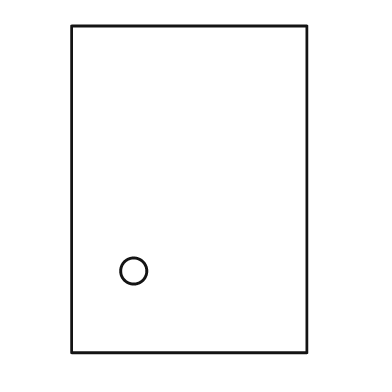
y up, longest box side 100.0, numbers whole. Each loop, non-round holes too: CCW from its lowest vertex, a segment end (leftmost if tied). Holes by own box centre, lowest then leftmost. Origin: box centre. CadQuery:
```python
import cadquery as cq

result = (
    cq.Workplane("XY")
    .moveTo(-36.0, -50.0)
    .lineTo(36.0, -50.0)
    .lineTo(36.0, 50.0)
    .lineTo(-36.0, 50.0)
    .close()
    .moveTo(-17.0, -25.0)
    .circle(4.0)
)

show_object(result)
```